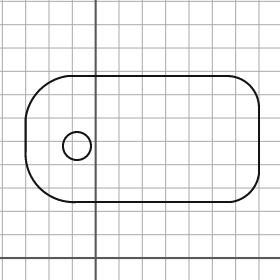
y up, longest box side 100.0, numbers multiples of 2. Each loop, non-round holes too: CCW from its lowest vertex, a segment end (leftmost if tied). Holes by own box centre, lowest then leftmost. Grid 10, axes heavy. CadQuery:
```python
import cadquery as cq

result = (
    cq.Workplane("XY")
    .moveTo(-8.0, 24.0)
    .lineTo(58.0, 24.0)
    .threePointArc((66.0, 28.0), (70.0, 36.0))
    .lineTo(70.0, 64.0)
    .threePointArc((66.0, 74.0), (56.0, 78.0))
    .lineTo(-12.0, 78.0)
    .threePointArc((-24.0, 72.0), (-30.0, 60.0))
    .lineTo(-30.0, 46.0)
    .threePointArc((-24.0, 30.0), (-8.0, 24.0))
    .close()
    .moveTo(-8.0, 48.0)
    .circle(6.0)
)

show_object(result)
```